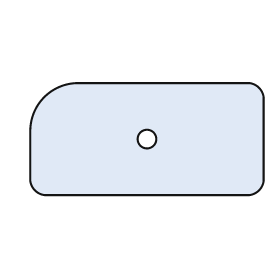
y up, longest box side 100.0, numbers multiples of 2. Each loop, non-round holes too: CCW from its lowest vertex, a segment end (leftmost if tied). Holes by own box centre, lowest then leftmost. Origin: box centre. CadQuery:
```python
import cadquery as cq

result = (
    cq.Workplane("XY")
    .moveTo(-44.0, -24.0)
    .lineTo(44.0, -24.0)
    .threePointArc((48.0, -22.0), (50.0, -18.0))
    .lineTo(50.0, 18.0)
    .threePointArc((48.0, 22.0), (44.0, 24.0))
    .lineTo(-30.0, 24.0)
    .threePointArc((-44.0, 18.0), (-50.0, 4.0))
    .lineTo(-50.0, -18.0)
    .threePointArc((-48.0, -22.0), (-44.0, -24.0))
    .close()
    .moveTo(0.0, 0.0)
    .circle(4.0)
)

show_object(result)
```